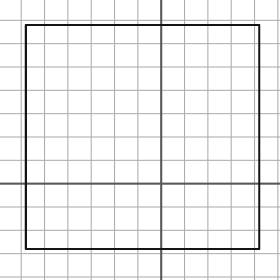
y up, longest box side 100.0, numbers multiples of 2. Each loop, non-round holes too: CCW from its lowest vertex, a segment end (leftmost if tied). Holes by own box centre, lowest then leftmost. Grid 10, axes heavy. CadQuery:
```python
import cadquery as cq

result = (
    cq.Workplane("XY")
    .moveTo(-58.0, -28.0)
    .lineTo(42.0, -28.0)
    .lineTo(42.0, 68.0)
    .lineTo(-58.0, 68.0)
    .close()
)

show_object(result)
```